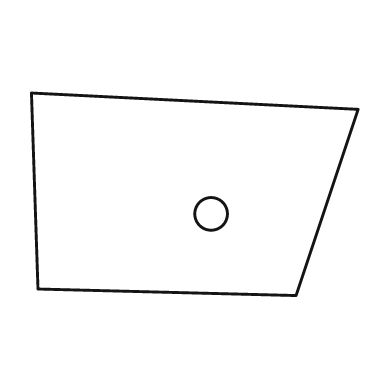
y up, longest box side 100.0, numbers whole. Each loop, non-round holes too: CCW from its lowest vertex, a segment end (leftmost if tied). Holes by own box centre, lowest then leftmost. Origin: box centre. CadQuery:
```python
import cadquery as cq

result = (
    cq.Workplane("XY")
    .moveTo(31.0, -31.0)
    .lineTo(50.0, 26.0)
    .lineTo(-50.0, 31.0)
    .lineTo(-48.0, -29.0)
    .close()
    .moveTo(5.0, -6.0)
    .circle(5.0)
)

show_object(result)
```